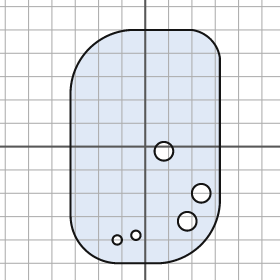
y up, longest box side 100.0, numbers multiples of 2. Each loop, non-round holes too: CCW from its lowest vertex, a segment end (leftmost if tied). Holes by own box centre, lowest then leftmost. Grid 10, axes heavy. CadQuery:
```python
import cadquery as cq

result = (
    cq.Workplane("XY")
    .moveTo(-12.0, -50.0)
    .lineTo(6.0, -50.0)
    .threePointArc((24.0, -42.0), (32.0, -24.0))
    .lineTo(32.0, 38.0)
    .threePointArc((28.0, 46.0), (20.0, 50.0))
    .lineTo(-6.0, 50.0)
    .threePointArc((-24.0, 42.0), (-32.0, 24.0))
    .lineTo(-32.0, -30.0)
    .threePointArc((-26.0, -44.0), (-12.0, -50.0))
    .close()
    .moveTo(-12.0, -40.0)
    .circle(2.0)
    .moveTo(-4.0, -38.0)
    .circle(2.0)
    .moveTo(18.0, -32.0)
    .circle(4.0)
    .moveTo(24.0, -20.0)
    .circle(4.0)
    .moveTo(8.0, -2.0)
    .circle(4.0)
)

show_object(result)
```